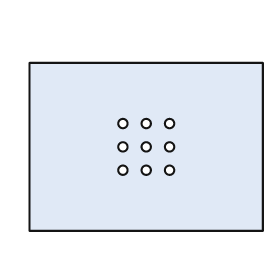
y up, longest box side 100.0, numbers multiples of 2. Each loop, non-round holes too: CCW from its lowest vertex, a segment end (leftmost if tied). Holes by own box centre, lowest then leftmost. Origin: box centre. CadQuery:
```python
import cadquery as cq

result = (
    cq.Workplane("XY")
    .moveTo(-50.0, -36.0)
    .lineTo(50.0, -36.0)
    .lineTo(50.0, 36.0)
    .lineTo(-50.0, 36.0)
    .close()
    .moveTo(-10.0, -10.0)
    .circle(2.0)
    .moveTo(0.0, -10.0)
    .circle(2.0)
    .moveTo(10.0, -10.0)
    .circle(2.0)
    .moveTo(-10.0, 0.0)
    .circle(2.0)
    .moveTo(0.0, 0.0)
    .circle(2.0)
    .moveTo(10.0, 0.0)
    .circle(2.0)
    .moveTo(-10.0, 10.0)
    .circle(2.0)
    .moveTo(0.0, 10.0)
    .circle(2.0)
    .moveTo(10.0, 10.0)
    .circle(2.0)
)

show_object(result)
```